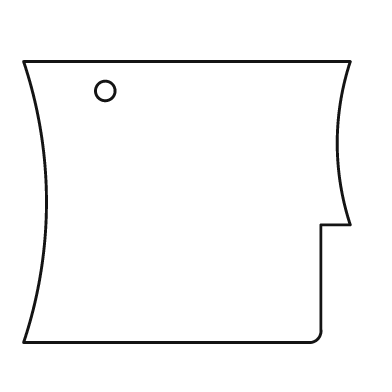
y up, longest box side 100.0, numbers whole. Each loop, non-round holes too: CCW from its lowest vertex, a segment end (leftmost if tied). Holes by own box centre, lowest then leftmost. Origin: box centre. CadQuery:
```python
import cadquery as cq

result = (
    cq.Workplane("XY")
    .moveTo(-50.0, -43.0)
    .lineTo(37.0, -43.0)
    .threePointArc((40.0, -42.0), (41.0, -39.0))
    .lineTo(41.0, -7.0)
    .lineTo(50.0, -7.0)
    .threePointArc((46.0, 18.0), (50.0, 43.0))
    .lineTo(-50.0, 43.0)
    .threePointArc((-43.0, 0.0), (-50.0, -43.0))
    .close()
    .moveTo(-25.0, 34.0)
    .circle(3.0)
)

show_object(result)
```